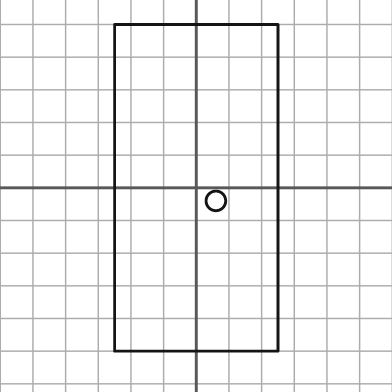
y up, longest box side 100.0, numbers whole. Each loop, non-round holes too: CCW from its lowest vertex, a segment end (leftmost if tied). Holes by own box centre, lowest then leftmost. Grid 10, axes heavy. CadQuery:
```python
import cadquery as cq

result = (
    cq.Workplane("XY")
    .moveTo(-25.0, -50.0)
    .lineTo(25.0, -50.0)
    .lineTo(25.0, 50.0)
    .lineTo(-25.0, 50.0)
    .close()
    .moveTo(6.0, -4.0)
    .circle(3.0)
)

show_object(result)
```